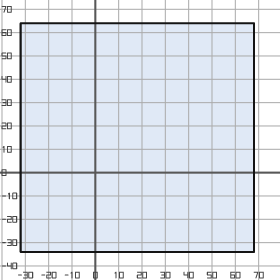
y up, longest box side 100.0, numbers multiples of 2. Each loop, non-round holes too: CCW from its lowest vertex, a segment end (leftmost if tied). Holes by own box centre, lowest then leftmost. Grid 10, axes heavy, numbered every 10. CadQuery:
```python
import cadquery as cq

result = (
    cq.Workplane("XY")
    .moveTo(-32.0, -34.0)
    .lineTo(68.0, -34.0)
    .lineTo(68.0, 64.0)
    .lineTo(-32.0, 64.0)
    .close()
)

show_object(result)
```